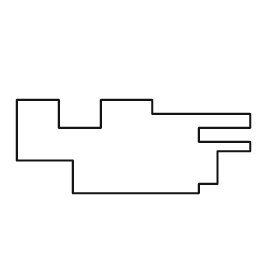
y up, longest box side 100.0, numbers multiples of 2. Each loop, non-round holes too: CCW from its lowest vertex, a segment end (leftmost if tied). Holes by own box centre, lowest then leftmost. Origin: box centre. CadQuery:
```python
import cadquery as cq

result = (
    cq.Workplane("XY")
    .moveTo(-26.0, -20.0)
    .lineTo(28.0, -20.0)
    .lineTo(28.0, -16.0)
    .lineTo(36.0, -16.0)
    .lineTo(36.0, -2.0)
    .lineTo(50.0, -2.0)
    .lineTo(50.0, 2.0)
    .lineTo(28.0, 2.0)
    .lineTo(28.0, 8.0)
    .lineTo(50.0, 8.0)
    .lineTo(50.0, 14.0)
    .lineTo(8.0, 14.0)
    .lineTo(8.0, 20.0)
    .lineTo(-14.0, 20.0)
    .lineTo(-14.0, 8.0)
    .lineTo(-32.0, 8.0)
    .lineTo(-32.0, 20.0)
    .lineTo(-50.0, 20.0)
    .lineTo(-50.0, -6.0)
    .lineTo(-26.0, -6.0)
    .close()
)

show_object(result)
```